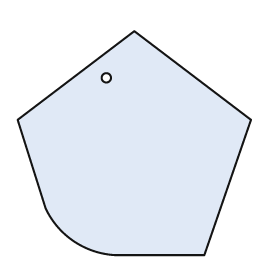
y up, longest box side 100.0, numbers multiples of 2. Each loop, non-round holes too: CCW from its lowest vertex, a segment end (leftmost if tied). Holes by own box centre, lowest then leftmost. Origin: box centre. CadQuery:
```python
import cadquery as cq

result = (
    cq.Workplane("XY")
    .moveTo(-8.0, -48.0)
    .lineTo(30.0, -48.0)
    .lineTo(50.0, 10.0)
    .lineTo(0.0, 48.0)
    .lineTo(-50.0, 10.0)
    .lineTo(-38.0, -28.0)
    .threePointArc((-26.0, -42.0), (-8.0, -48.0))
    .close()
    .moveTo(-12.0, 28.0)
    .circle(2.0)
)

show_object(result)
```